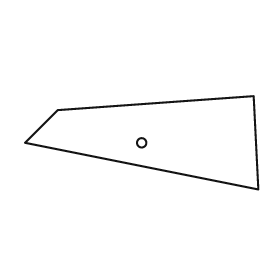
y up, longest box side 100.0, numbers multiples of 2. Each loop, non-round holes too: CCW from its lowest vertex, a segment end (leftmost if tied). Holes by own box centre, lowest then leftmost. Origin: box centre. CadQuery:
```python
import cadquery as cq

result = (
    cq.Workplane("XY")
    .moveTo(50.0, -20.0)
    .lineTo(48.0, 20.0)
    .lineTo(-36.0, 14.0)
    .lineTo(-50.0, 0.0)
    .close()
    .moveTo(0.0, 0.0)
    .circle(2.0)
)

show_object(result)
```